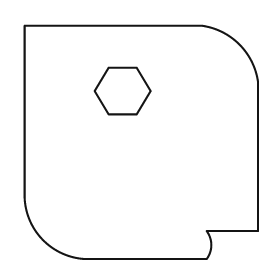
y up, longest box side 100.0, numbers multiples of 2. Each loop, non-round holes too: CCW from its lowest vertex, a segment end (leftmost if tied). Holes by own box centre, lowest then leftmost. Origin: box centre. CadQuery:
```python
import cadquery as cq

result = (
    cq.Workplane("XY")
    .moveTo(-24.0, -50.0)
    .lineTo(28.0, -50.0)
    .threePointArc((30.0, -44.0), (28.0, -38.0))
    .lineTo(50.0, -38.0)
    .lineTo(50.0, 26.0)
    .threePointArc((42.0, 42.0), (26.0, 50.0))
    .lineTo(-50.0, 50.0)
    .lineTo(-50.0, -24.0)
    .threePointArc((-42.0, -42.0), (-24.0, -50.0))
    .close()
    .moveTo(-14.0, 12.0)
    .lineTo(-2.0, 12.0)
    .lineTo(4.0, 22.0)
    .lineTo(-2.0, 32.0)
    .lineTo(-14.0, 32.0)
    .lineTo(-20.0, 22.0)
    .close()
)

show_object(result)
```